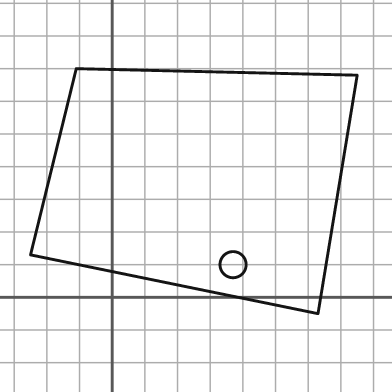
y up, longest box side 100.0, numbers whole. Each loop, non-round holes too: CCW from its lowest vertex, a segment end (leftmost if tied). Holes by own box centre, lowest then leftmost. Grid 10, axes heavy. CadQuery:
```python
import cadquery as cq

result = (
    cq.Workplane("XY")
    .moveTo(63.0, -5.0)
    .lineTo(75.0, 68.0)
    .lineTo(-11.0, 70.0)
    .lineTo(-25.0, 13.0)
    .close()
    .moveTo(37.0, 10.0)
    .circle(4.0)
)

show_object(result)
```